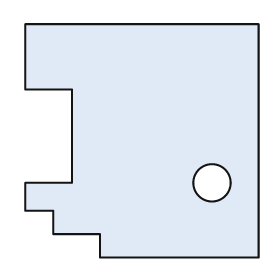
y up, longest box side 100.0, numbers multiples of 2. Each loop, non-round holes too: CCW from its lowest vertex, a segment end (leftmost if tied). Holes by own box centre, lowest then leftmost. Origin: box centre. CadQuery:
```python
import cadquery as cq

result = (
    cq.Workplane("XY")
    .moveTo(-18.0, -50.0)
    .lineTo(50.0, -50.0)
    .lineTo(50.0, 50.0)
    .lineTo(-50.0, 50.0)
    .lineTo(-50.0, 22.0)
    .lineTo(-30.0, 22.0)
    .lineTo(-30.0, -18.0)
    .lineTo(-50.0, -18.0)
    .lineTo(-50.0, -30.0)
    .lineTo(-38.0, -30.0)
    .lineTo(-38.0, -40.0)
    .lineTo(-18.0, -40.0)
    .close()
    .moveTo(30.0, -18.0)
    .circle(8.0)
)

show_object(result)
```